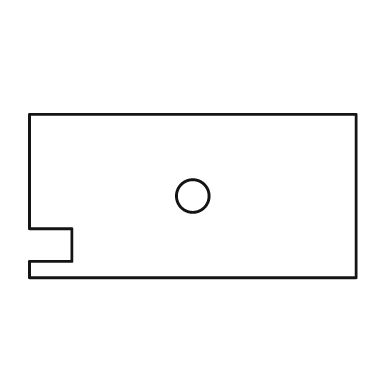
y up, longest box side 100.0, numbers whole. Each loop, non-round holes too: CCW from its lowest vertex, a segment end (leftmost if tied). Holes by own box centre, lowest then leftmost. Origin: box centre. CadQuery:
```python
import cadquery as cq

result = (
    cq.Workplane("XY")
    .moveTo(-50.0, -25.0)
    .lineTo(50.0, -25.0)
    .lineTo(50.0, 25.0)
    .lineTo(-50.0, 25.0)
    .lineTo(-50.0, -10.0)
    .lineTo(-37.0, -10.0)
    .lineTo(-37.0, -20.0)
    .lineTo(-50.0, -20.0)
    .close()
    .moveTo(0.0, 0.0)
    .circle(5.0)
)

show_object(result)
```